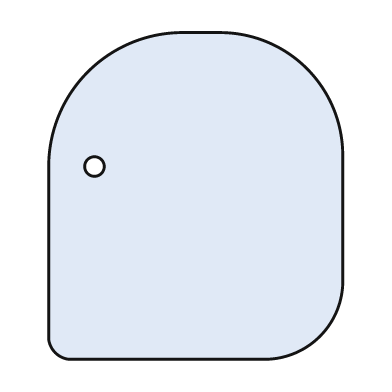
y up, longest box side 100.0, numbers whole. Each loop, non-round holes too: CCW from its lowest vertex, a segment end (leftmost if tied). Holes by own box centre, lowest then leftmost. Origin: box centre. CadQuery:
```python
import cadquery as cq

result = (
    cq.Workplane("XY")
    .moveTo(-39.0, -50.0)
    .lineTo(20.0, -50.0)
    .threePointArc((38.0, -43.0), (45.0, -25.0))
    .lineTo(45.0, 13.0)
    .threePointArc((34.0, 39.0), (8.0, 50.0))
    .lineTo(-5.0, 50.0)
    .threePointArc((-33.0, 38.0), (-45.0, 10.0))
    .lineTo(-45.0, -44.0)
    .threePointArc((-43.0, -48.0), (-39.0, -50.0))
    .close()
    .moveTo(-31.0, 9.0)
    .circle(3.0)
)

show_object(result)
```